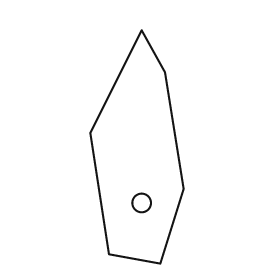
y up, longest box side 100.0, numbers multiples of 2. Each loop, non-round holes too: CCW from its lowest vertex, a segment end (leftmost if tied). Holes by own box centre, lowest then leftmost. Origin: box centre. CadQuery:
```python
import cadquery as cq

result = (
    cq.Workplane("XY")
    .moveTo(10.0, -50.0)
    .lineTo(20.0, -18.0)
    .lineTo(12.0, 32.0)
    .lineTo(2.0, 50.0)
    .lineTo(-20.0, 6.0)
    .lineTo(-12.0, -46.0)
    .close()
    .moveTo(2.0, -24.0)
    .circle(4.0)
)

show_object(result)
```